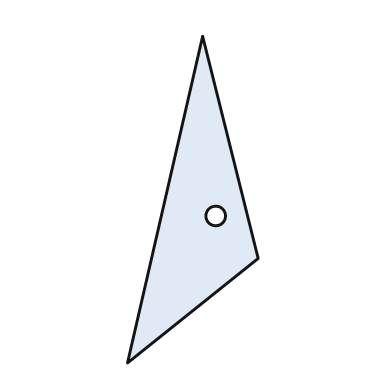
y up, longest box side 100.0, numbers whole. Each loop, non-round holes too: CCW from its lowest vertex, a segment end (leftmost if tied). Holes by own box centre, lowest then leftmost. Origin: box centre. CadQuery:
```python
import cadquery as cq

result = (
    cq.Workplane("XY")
    .moveTo(-20.0, -50.0)
    .lineTo(20.0, -18.0)
    .lineTo(3.0, 50.0)
    .close()
    .moveTo(7.0, -5.0)
    .circle(3.0)
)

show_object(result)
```